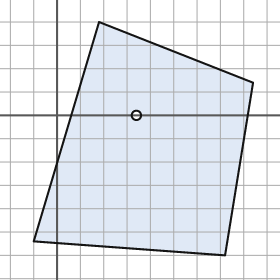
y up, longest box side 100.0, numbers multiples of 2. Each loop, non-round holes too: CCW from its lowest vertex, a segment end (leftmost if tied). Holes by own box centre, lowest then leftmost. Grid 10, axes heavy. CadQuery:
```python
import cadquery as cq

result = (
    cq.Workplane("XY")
    .moveTo(72.0, -60.0)
    .lineTo(84.0, 14.0)
    .lineTo(18.0, 40.0)
    .lineTo(-10.0, -54.0)
    .close()
    .moveTo(34.0, 0.0)
    .circle(2.0)
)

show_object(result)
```